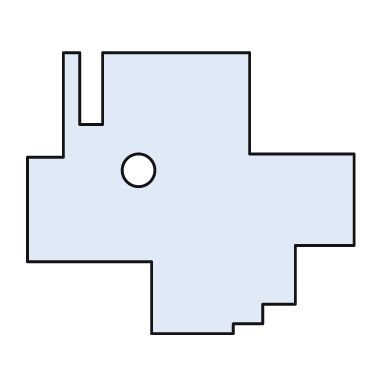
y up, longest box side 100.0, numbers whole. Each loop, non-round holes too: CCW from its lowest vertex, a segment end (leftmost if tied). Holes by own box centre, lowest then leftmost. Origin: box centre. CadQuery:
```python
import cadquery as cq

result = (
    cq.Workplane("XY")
    .moveTo(-12.0, -43.0)
    .lineTo(13.0, -43.0)
    .lineTo(13.0, -40.0)
    .lineTo(22.0, -40.0)
    .lineTo(22.0, -34.0)
    .lineTo(32.0, -34.0)
    .lineTo(32.0, -16.0)
    .lineTo(50.0, -16.0)
    .lineTo(50.0, 12.0)
    .lineTo(18.0, 12.0)
    .lineTo(18.0, 43.0)
    .lineTo(-27.0, 43.0)
    .lineTo(-27.0, 21.0)
    .lineTo(-34.0, 21.0)
    .lineTo(-34.0, 43.0)
    .lineTo(-39.0, 43.0)
    .lineTo(-39.0, 11.0)
    .lineTo(-50.0, 11.0)
    .lineTo(-50.0, -21.0)
    .lineTo(-12.0, -21.0)
    .close()
    .moveTo(-16.0, 7.0)
    .circle(5.0)
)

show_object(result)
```